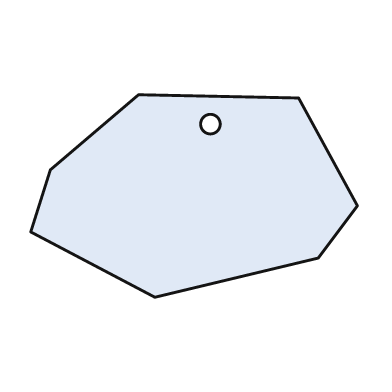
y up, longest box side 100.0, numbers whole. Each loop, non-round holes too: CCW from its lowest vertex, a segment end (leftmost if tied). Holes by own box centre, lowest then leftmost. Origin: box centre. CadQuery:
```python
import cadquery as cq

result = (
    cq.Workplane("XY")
    .moveTo(-12.0, -31.0)
    .lineTo(38.0, -19.0)
    .lineTo(50.0, -3.0)
    .lineTo(32.0, 30.0)
    .lineTo(-17.0, 31.0)
    .lineTo(-44.0, 8.0)
    .lineTo(-50.0, -11.0)
    .close()
    .moveTo(5.0, 22.0)
    .circle(3.0)
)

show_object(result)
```